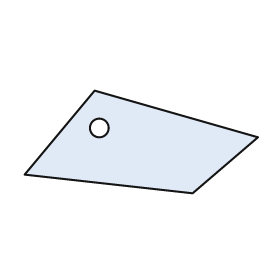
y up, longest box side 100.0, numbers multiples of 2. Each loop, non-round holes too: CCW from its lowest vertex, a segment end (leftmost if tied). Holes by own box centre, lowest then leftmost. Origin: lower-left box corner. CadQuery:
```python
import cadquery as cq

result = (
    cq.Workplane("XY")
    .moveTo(72.0, 0.0)
    .lineTo(100.0, 24.0)
    .lineTo(30.0, 44.0)
    .lineTo(0.0, 8.0)
    .close()
    .moveTo(32.0, 28.0)
    .circle(4.0)
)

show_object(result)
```